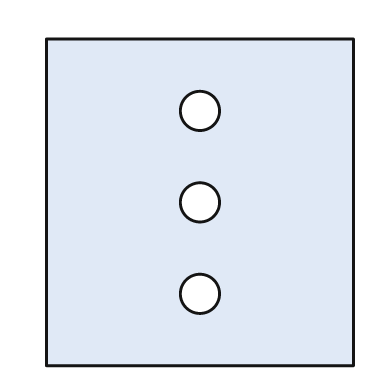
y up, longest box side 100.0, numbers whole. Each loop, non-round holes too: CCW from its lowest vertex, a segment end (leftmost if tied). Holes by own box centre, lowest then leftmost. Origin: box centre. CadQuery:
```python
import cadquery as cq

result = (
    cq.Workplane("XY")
    .moveTo(-47.0, -50.0)
    .lineTo(47.0, -50.0)
    .lineTo(47.0, 50.0)
    .lineTo(-47.0, 50.0)
    .close()
    .moveTo(0.0, -28.0)
    .circle(6.0)
    .moveTo(0.0, 0.0)
    .circle(6.0)
    .moveTo(0.0, 28.0)
    .circle(6.0)
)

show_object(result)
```